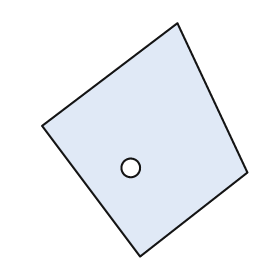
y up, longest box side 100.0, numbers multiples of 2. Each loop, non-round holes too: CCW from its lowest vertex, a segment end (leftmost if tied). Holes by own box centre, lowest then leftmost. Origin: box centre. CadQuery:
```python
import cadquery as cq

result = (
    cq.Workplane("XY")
    .moveTo(-2.0, -50.0)
    .lineTo(44.0, -14.0)
    .lineTo(14.0, 50.0)
    .lineTo(-44.0, 6.0)
    .close()
    .moveTo(-6.0, -12.0)
    .circle(4.0)
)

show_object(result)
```